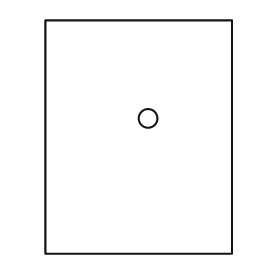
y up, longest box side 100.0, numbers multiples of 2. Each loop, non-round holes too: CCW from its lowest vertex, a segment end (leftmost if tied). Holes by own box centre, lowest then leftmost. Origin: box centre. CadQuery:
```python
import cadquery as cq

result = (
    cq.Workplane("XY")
    .moveTo(-40.0, -50.0)
    .lineTo(40.0, -50.0)
    .lineTo(40.0, 50.0)
    .lineTo(-40.0, 50.0)
    .close()
    .moveTo(4.0, 8.0)
    .circle(4.0)
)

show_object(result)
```